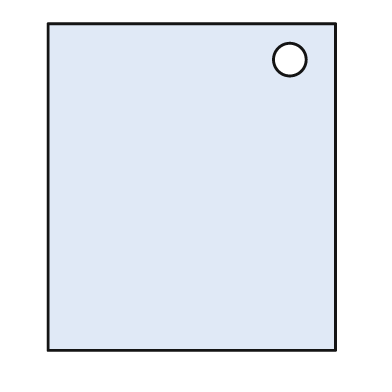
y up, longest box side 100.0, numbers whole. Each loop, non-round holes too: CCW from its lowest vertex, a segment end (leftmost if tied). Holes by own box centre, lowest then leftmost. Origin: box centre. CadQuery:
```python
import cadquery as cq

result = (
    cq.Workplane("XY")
    .moveTo(-44.0, -50.0)
    .lineTo(44.0, -50.0)
    .lineTo(44.0, 50.0)
    .lineTo(-44.0, 50.0)
    .close()
    .moveTo(30.0, 39.0)
    .circle(5.0)
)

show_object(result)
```